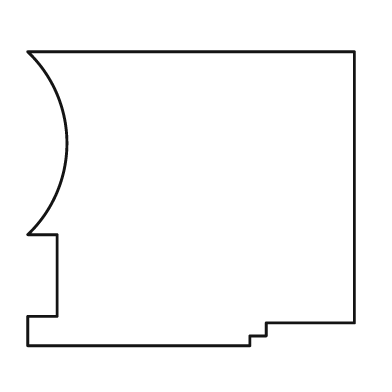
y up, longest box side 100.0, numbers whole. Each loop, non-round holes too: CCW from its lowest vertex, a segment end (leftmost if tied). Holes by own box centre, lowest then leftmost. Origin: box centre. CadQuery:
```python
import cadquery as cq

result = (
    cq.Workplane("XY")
    .moveTo(-50.0, -45.0)
    .lineTo(18.0, -45.0)
    .lineTo(18.0, -42.0)
    .lineTo(23.0, -42.0)
    .lineTo(23.0, -38.0)
    .lineTo(50.0, -38.0)
    .lineTo(50.0, 45.0)
    .lineTo(-50.0, 45.0)
    .threePointArc((-38.0, 17.0), (-50.0, -11.0))
    .lineTo(-41.0, -11.0)
    .lineTo(-41.0, -36.0)
    .lineTo(-50.0, -36.0)
    .close()
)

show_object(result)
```